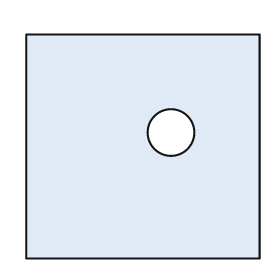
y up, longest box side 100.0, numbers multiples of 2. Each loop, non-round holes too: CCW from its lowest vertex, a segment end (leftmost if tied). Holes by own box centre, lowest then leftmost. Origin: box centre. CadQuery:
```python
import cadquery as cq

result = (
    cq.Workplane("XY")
    .moveTo(-50.0, -48.0)
    .lineTo(50.0, -48.0)
    .lineTo(50.0, 48.0)
    .lineTo(-50.0, 48.0)
    .close()
    .moveTo(12.0, 6.0)
    .circle(10.0)
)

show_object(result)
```